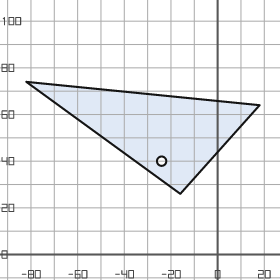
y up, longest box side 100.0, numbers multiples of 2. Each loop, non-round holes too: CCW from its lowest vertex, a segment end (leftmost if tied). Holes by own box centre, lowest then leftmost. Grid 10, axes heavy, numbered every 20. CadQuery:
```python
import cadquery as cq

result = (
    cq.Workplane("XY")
    .moveTo(-16.0, 26.0)
    .lineTo(18.0, 64.0)
    .lineTo(-82.0, 74.0)
    .close()
    .moveTo(-24.0, 40.0)
    .circle(2.0)
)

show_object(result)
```